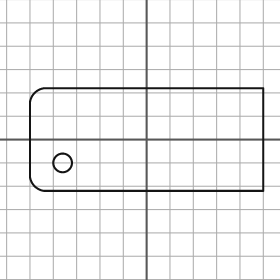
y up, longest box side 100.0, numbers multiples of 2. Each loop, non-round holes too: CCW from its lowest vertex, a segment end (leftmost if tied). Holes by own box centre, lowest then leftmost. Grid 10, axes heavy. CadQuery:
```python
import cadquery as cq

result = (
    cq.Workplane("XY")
    .moveTo(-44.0, -22.0)
    .lineTo(50.0, -22.0)
    .lineTo(50.0, 22.0)
    .lineTo(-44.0, 22.0)
    .threePointArc((-48.0, 20.0), (-50.0, 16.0))
    .lineTo(-50.0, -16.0)
    .threePointArc((-48.0, -20.0), (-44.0, -22.0))
    .close()
    .moveTo(-36.0, -10.0)
    .circle(4.0)
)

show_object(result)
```